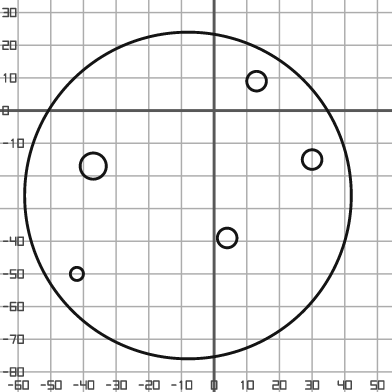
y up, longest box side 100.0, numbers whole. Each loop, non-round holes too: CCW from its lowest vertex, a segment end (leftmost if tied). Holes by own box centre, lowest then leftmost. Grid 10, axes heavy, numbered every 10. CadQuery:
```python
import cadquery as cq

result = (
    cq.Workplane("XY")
    .moveTo(-8.0, -26.0)
    .circle(50.0)
    .moveTo(-42.0, -50.0)
    .circle(2.0)
    .moveTo(4.0, -39.0)
    .circle(3.0)
    .moveTo(-37.0, -17.0)
    .circle(4.0)
    .moveTo(30.0, -15.0)
    .circle(3.0)
    .moveTo(13.0, 9.0)
    .circle(3.0)
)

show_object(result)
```